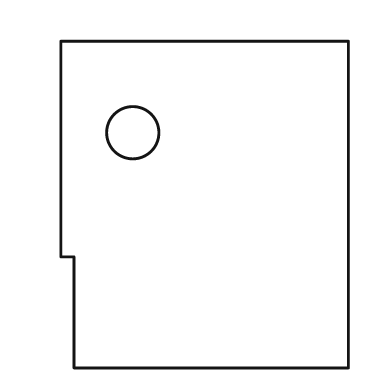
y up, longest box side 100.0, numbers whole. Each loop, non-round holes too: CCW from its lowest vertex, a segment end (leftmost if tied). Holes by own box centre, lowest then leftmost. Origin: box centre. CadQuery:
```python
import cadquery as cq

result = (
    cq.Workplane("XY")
    .moveTo(-40.0, -50.0)
    .lineTo(44.0, -50.0)
    .lineTo(44.0, 50.0)
    .lineTo(-44.0, 50.0)
    .lineTo(-44.0, -16.0)
    .lineTo(-40.0, -16.0)
    .close()
    .moveTo(-22.0, 22.0)
    .circle(8.0)
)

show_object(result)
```